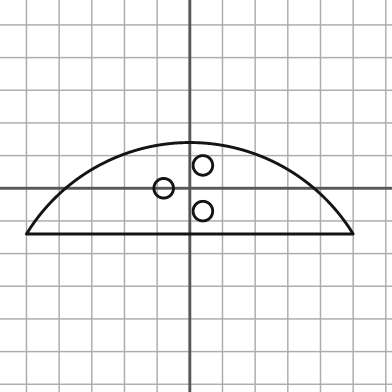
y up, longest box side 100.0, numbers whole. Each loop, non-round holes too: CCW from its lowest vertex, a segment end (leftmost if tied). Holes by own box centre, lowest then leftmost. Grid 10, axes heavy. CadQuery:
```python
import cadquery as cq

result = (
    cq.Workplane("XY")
    .moveTo(-50.0, -14.0)
    .lineTo(50.0, -14.0)
    .threePointArc((0.0, 14.0), (-50.0, -14.0))
    .close()
    .moveTo(4.0, -7.0)
    .circle(3.0)
    .moveTo(-8.0, 0.0)
    .circle(3.0)
    .moveTo(4.0, 7.0)
    .circle(3.0)
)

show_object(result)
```